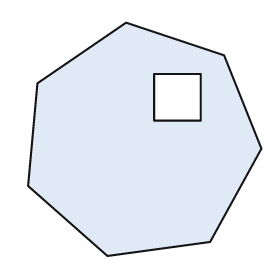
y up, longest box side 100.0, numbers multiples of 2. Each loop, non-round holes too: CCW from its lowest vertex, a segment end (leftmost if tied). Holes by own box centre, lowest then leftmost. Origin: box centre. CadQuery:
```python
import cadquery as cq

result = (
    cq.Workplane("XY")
    .moveTo(-16.0, -50.0)
    .lineTo(28.0, -44.0)
    .lineTo(50.0, -4.0)
    .lineTo(34.0, 36.0)
    .lineTo(-8.0, 50.0)
    .lineTo(-46.0, 24.0)
    .lineTo(-50.0, -20.0)
    .close()
    .moveTo(4.0, 8.0)
    .lineTo(24.0, 8.0)
    .lineTo(24.0, 28.0)
    .lineTo(4.0, 28.0)
    .close()
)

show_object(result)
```